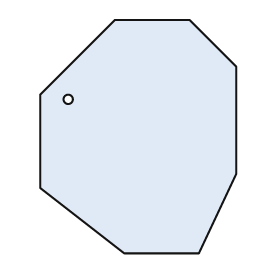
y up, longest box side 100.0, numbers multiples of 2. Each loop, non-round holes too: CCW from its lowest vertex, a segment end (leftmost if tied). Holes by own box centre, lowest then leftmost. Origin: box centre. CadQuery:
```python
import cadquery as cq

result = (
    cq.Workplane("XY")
    .moveTo(-6.0, -50.0)
    .lineTo(26.0, -50.0)
    .lineTo(42.0, -16.0)
    .lineTo(42.0, 30.0)
    .lineTo(22.0, 50.0)
    .lineTo(-10.0, 50.0)
    .lineTo(-42.0, 18.0)
    .lineTo(-42.0, -22.0)
    .close()
    .moveTo(-30.0, 16.0)
    .circle(2.0)
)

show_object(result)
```